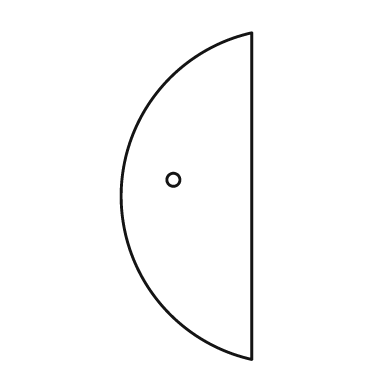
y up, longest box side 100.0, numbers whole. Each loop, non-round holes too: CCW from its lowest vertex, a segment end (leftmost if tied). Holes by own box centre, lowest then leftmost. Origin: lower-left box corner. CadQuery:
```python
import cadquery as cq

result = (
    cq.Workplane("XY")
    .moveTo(40.0, 0.0)
    .lineTo(40.0, 100.0)
    .threePointArc((0.0, 50.0), (40.0, 0.0))
    .close()
    .moveTo(16.0, 55.0)
    .circle(2.0)
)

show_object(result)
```